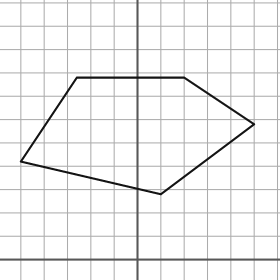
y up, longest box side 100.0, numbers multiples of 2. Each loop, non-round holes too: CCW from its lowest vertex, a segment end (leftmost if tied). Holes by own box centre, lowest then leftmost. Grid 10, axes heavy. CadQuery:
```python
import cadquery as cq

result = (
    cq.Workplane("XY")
    .moveTo(10.0, 28.0)
    .lineTo(50.0, 58.0)
    .lineTo(20.0, 78.0)
    .lineTo(-26.0, 78.0)
    .lineTo(-50.0, 42.0)
    .close()
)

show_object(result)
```